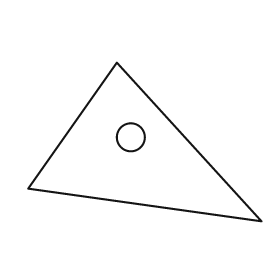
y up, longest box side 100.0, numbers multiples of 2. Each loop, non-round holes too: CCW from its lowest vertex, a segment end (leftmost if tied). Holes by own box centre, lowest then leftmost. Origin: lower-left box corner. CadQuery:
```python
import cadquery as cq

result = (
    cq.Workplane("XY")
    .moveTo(100.0, 0.0)
    .lineTo(38.0, 68.0)
    .lineTo(0.0, 14.0)
    .close()
    .moveTo(44.0, 36.0)
    .circle(6.0)
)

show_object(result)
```